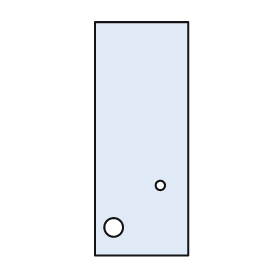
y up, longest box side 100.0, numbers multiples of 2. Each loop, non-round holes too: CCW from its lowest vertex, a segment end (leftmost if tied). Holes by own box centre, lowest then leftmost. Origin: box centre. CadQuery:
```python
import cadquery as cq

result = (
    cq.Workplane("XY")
    .moveTo(-20.0, -50.0)
    .lineTo(20.0, -50.0)
    .lineTo(20.0, 50.0)
    .lineTo(-20.0, 50.0)
    .close()
    .moveTo(-12.0, -38.0)
    .circle(4.0)
    .moveTo(8.0, -20.0)
    .circle(2.0)
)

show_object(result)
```